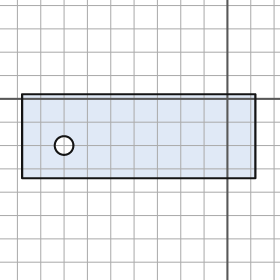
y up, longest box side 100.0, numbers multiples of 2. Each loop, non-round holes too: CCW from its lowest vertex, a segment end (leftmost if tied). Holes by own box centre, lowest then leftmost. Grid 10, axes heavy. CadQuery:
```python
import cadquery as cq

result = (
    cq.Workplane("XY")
    .moveTo(-88.0, -34.0)
    .lineTo(12.0, -34.0)
    .lineTo(12.0, 2.0)
    .lineTo(-88.0, 2.0)
    .close()
    .moveTo(-70.0, -20.0)
    .circle(4.0)
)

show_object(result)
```